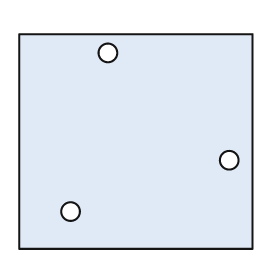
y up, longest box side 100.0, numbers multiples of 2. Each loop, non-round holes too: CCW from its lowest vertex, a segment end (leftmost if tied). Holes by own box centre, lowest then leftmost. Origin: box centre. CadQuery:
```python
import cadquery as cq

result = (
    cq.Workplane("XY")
    .moveTo(-50.0, -46.0)
    .lineTo(50.0, -46.0)
    .lineTo(50.0, 46.0)
    .lineTo(-50.0, 46.0)
    .close()
    .moveTo(-28.0, -30.0)
    .circle(4.0)
    .moveTo(40.0, -8.0)
    .circle(4.0)
    .moveTo(-12.0, 38.0)
    .circle(4.0)
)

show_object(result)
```